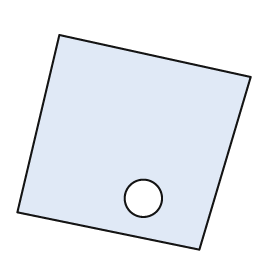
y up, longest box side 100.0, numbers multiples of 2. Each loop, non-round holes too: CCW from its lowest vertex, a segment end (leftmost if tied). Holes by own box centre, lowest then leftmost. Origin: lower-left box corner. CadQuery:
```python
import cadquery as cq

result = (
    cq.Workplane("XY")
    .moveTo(78.0, 0.0)
    .lineTo(100.0, 74.0)
    .lineTo(18.0, 92.0)
    .lineTo(0.0, 16.0)
    .close()
    .moveTo(54.0, 22.0)
    .circle(8.0)
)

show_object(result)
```